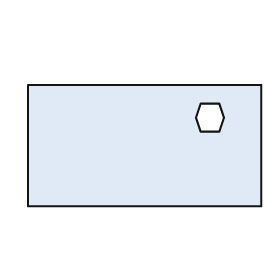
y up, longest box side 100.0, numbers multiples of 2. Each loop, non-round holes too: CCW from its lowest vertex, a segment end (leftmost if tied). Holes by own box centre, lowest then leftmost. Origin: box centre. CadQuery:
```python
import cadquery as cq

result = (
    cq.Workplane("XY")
    .moveTo(-50.0, -26.0)
    .lineTo(50.0, -26.0)
    .lineTo(50.0, 26.0)
    .lineTo(-50.0, 26.0)
    .close()
    .moveTo(24.0, 6.0)
    .lineTo(32.0, 6.0)
    .lineTo(34.0, 12.0)
    .lineTo(32.0, 18.0)
    .lineTo(24.0, 18.0)
    .lineTo(22.0, 12.0)
    .close()
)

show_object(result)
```